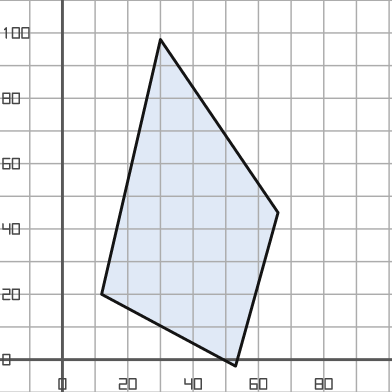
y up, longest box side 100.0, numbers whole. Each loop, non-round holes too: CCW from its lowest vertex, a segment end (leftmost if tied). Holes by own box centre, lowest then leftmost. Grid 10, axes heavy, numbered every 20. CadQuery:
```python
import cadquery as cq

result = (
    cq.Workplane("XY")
    .moveTo(53.0, -2.0)
    .lineTo(66.0, 45.0)
    .lineTo(30.0, 98.0)
    .lineTo(12.0, 20.0)
    .close()
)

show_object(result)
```